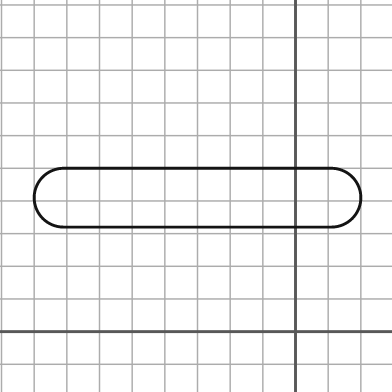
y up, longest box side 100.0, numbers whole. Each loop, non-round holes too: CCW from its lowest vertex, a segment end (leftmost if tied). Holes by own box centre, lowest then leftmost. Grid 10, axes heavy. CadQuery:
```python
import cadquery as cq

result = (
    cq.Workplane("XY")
    .moveTo(-71.0, 32.0)
    .lineTo(11.0, 32.0)
    .threePointArc((20.0, 41.0), (11.0, 50.0))
    .lineTo(-71.0, 50.0)
    .threePointArc((-80.0, 41.0), (-71.0, 32.0))
    .close()
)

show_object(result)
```